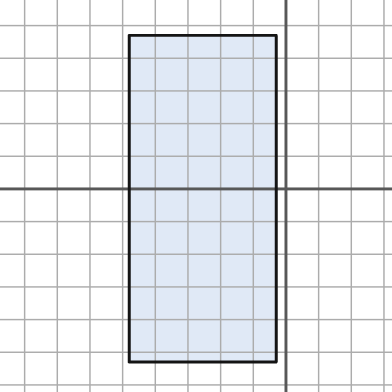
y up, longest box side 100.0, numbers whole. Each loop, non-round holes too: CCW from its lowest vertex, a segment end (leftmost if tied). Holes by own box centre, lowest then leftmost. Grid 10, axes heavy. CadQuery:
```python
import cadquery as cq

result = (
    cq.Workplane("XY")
    .moveTo(-48.0, -53.0)
    .lineTo(-3.0, -53.0)
    .lineTo(-3.0, 47.0)
    .lineTo(-48.0, 47.0)
    .close()
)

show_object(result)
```